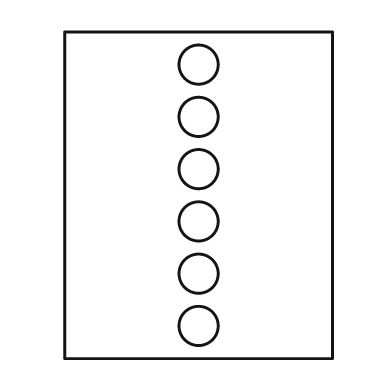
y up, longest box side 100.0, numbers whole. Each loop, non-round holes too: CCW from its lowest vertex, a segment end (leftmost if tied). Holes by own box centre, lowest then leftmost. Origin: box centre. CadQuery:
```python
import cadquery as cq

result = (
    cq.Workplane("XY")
    .moveTo(-41.0, -50.0)
    .lineTo(41.0, -50.0)
    .lineTo(41.0, 50.0)
    .lineTo(-41.0, 50.0)
    .close()
    .moveTo(0.0, -40.0)
    .circle(6.0)
    .moveTo(0.0, -24.0)
    .circle(6.0)
    .moveTo(0.0, -8.0)
    .circle(6.0)
    .moveTo(0.0, 8.0)
    .circle(6.0)
    .moveTo(0.0, 24.0)
    .circle(6.0)
    .moveTo(0.0, 40.0)
    .circle(6.0)
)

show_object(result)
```